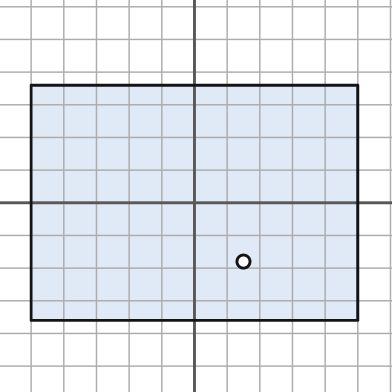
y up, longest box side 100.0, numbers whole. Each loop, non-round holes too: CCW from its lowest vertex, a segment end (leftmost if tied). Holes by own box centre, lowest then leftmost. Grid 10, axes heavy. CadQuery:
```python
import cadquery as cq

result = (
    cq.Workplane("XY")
    .moveTo(-50.0, -36.0)
    .lineTo(50.0, -36.0)
    .lineTo(50.0, 36.0)
    .lineTo(-50.0, 36.0)
    .close()
    .moveTo(15.0, -18.0)
    .circle(2.0)
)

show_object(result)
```